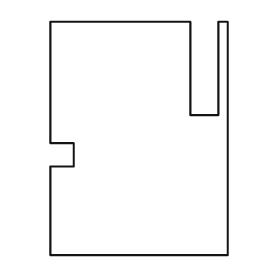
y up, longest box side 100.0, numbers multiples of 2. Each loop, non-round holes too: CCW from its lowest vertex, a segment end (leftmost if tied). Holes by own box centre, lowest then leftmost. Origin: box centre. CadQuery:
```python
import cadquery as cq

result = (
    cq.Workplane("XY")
    .moveTo(-38.0, -50.0)
    .lineTo(38.0, -50.0)
    .lineTo(38.0, 50.0)
    .lineTo(34.0, 50.0)
    .lineTo(34.0, 10.0)
    .lineTo(22.0, 10.0)
    .lineTo(22.0, 50.0)
    .lineTo(-38.0, 50.0)
    .lineTo(-38.0, -2.0)
    .lineTo(-28.0, -2.0)
    .lineTo(-28.0, -12.0)
    .lineTo(-38.0, -12.0)
    .close()
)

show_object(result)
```